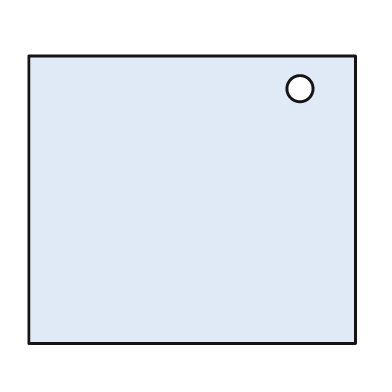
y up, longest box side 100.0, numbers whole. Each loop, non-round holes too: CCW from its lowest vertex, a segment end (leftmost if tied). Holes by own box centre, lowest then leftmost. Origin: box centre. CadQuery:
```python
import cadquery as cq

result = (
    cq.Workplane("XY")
    .moveTo(-50.0, -44.0)
    .lineTo(50.0, -44.0)
    .lineTo(50.0, 44.0)
    .lineTo(-50.0, 44.0)
    .close()
    .moveTo(33.0, 34.0)
    .circle(4.0)
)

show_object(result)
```